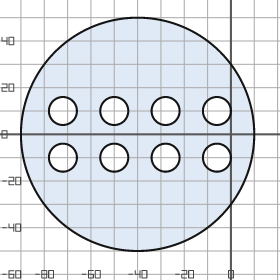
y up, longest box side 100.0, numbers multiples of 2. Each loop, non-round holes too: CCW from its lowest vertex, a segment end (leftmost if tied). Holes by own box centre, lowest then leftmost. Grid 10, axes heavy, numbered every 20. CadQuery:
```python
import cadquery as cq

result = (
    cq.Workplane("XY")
    .moveTo(-40.0, 0.0)
    .circle(50.0)
    .moveTo(-72.0, -10.0)
    .circle(6.0)
    .moveTo(-50.0, -10.0)
    .circle(6.0)
    .moveTo(-28.0, -10.0)
    .circle(6.0)
    .moveTo(-6.0, -10.0)
    .circle(6.0)
    .moveTo(-72.0, 10.0)
    .circle(6.0)
    .moveTo(-50.0, 10.0)
    .circle(6.0)
    .moveTo(-28.0, 10.0)
    .circle(6.0)
    .moveTo(-6.0, 10.0)
    .circle(6.0)
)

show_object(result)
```